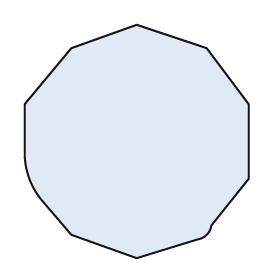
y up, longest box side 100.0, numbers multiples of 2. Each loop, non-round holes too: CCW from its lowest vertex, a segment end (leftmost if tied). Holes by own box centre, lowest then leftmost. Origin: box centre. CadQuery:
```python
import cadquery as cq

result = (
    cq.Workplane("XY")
    .moveTo(0.0, -50.0)
    .lineTo(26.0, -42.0)
    .threePointArc((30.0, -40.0), (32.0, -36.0))
    .lineTo(48.0, -16.0)
    .lineTo(48.0, 16.0)
    .lineTo(30.0, 40.0)
    .lineTo(0.0, 50.0)
    .lineTo(-28.0, 40.0)
    .lineTo(-48.0, 16.0)
    .lineTo(-48.0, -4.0)
    .threePointArc((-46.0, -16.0), (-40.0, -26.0))
    .lineTo(-28.0, -40.0)
    .close()
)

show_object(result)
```